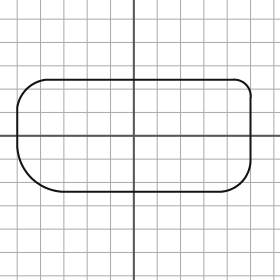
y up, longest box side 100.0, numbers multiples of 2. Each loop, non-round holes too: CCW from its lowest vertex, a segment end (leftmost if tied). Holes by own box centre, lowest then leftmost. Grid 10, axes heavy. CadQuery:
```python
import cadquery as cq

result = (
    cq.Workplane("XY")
    .moveTo(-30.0, -24.0)
    .lineTo(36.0, -24.0)
    .threePointArc((46.0, -20.0), (50.0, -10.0))
    .lineTo(50.0, 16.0)
    .threePointArc((48.0, 22.0), (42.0, 24.0))
    .lineTo(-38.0, 24.0)
    .threePointArc((-46.0, 20.0), (-50.0, 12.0))
    .lineTo(-50.0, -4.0)
    .threePointArc((-44.0, -18.0), (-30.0, -24.0))
    .close()
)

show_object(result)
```